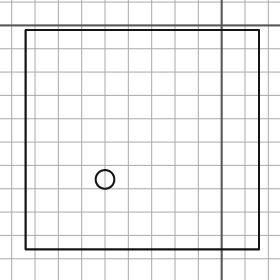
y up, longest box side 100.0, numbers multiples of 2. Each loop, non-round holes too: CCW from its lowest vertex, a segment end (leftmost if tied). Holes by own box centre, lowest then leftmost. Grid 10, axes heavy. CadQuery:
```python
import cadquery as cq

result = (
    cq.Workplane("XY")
    .moveTo(-84.0, -96.0)
    .lineTo(16.0, -96.0)
    .lineTo(16.0, -2.0)
    .lineTo(-84.0, -2.0)
    .close()
    .moveTo(-50.0, -66.0)
    .circle(4.0)
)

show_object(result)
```